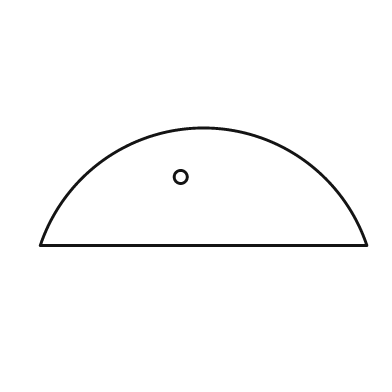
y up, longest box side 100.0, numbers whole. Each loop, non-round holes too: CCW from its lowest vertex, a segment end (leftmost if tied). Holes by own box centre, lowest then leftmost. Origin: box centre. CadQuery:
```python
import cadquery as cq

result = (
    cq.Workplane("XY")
    .moveTo(-50.0, -18.0)
    .lineTo(50.0, -18.0)
    .threePointArc((0.0, 18.0), (-50.0, -18.0))
    .close()
    .moveTo(-7.0, 3.0)
    .circle(2.0)
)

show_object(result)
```